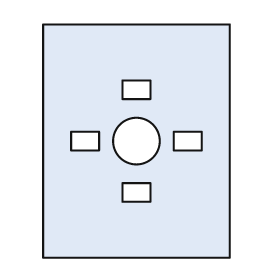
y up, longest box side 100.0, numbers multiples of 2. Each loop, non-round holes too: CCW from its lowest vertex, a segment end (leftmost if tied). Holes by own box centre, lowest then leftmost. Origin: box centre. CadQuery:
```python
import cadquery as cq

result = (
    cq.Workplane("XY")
    .moveTo(-40.0, -50.0)
    .lineTo(40.0, -50.0)
    .lineTo(40.0, 50.0)
    .lineTo(-40.0, 50.0)
    .close()
    .moveTo(-6.0, -26.0)
    .lineTo(6.0, -26.0)
    .lineTo(6.0, -18.0)
    .lineTo(-6.0, -18.0)
    .close()
    .moveTo(-28.0, -4.0)
    .lineTo(-16.0, -4.0)
    .lineTo(-16.0, 4.0)
    .lineTo(-28.0, 4.0)
    .close()
    .moveTo(0.0, 0.0)
    .circle(10.0)
    .moveTo(16.0, -4.0)
    .lineTo(28.0, -4.0)
    .lineTo(28.0, 4.0)
    .lineTo(16.0, 4.0)
    .close()
    .moveTo(-6.0, 18.0)
    .lineTo(6.0, 18.0)
    .lineTo(6.0, 26.0)
    .lineTo(-6.0, 26.0)
    .close()
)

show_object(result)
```